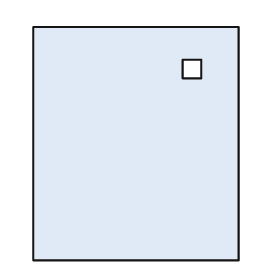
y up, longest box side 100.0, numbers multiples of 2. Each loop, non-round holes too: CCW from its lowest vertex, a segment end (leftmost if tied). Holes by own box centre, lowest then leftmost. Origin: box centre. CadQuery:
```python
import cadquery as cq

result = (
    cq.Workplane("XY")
    .moveTo(-44.0, -50.0)
    .lineTo(44.0, -50.0)
    .lineTo(44.0, 50.0)
    .lineTo(-44.0, 50.0)
    .close()
    .moveTo(20.0, 28.0)
    .lineTo(28.0, 28.0)
    .lineTo(28.0, 36.0)
    .lineTo(20.0, 36.0)
    .close()
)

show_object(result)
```